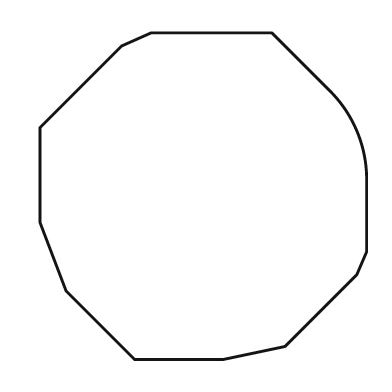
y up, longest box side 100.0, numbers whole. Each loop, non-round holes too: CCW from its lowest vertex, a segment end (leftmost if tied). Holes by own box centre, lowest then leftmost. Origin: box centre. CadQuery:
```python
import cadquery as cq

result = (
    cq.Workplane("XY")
    .moveTo(-21.0, -50.0)
    .lineTo(6.0, -50.0)
    .lineTo(25.0, -46.0)
    .lineTo(47.0, -24.0)
    .lineTo(50.0, -17.0)
    .lineTo(50.0, 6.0)
    .threePointArc((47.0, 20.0), (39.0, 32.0))
    .lineTo(21.0, 50.0)
    .lineTo(-16.0, 50.0)
    .lineTo(-25.0, 46.0)
    .lineTo(-50.0, 21.0)
    .lineTo(-50.0, -8.0)
    .lineTo(-42.0, -29.0)
    .close()
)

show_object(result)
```